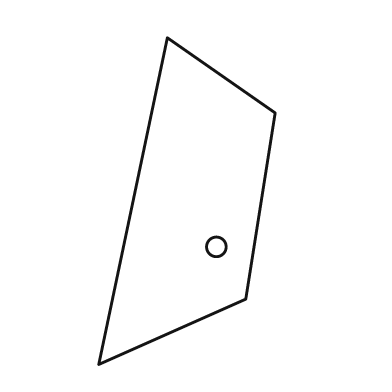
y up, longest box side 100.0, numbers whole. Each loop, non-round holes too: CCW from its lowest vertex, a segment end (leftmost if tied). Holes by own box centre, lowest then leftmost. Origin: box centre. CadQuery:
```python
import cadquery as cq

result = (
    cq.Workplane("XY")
    .moveTo(-27.0, -50.0)
    .lineTo(18.0, -30.0)
    .lineTo(27.0, 27.0)
    .lineTo(-6.0, 50.0)
    .close()
    .moveTo(9.0, -14.0)
    .circle(3.0)
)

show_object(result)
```